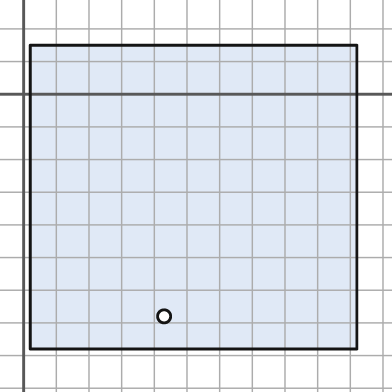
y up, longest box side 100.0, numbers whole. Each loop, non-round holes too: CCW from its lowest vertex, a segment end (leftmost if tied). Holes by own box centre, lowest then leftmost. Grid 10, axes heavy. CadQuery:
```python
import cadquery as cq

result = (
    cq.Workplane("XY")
    .moveTo(2.0, -78.0)
    .lineTo(102.0, -78.0)
    .lineTo(102.0, 15.0)
    .lineTo(2.0, 15.0)
    .close()
    .moveTo(43.0, -68.0)
    .circle(2.0)
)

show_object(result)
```